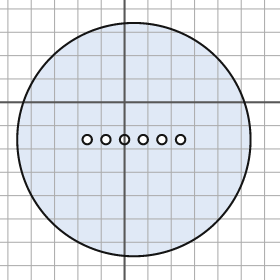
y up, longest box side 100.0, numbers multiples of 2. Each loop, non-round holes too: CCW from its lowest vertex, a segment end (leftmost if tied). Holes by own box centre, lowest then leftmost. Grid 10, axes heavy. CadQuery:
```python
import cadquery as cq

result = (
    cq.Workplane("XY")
    .moveTo(4.0, -16.0)
    .circle(50.0)
    .moveTo(-16.0, -16.0)
    .circle(2.0)
    .moveTo(-8.0, -16.0)
    .circle(2.0)
    .moveTo(0.0, -16.0)
    .circle(2.0)
    .moveTo(8.0, -16.0)
    .circle(2.0)
    .moveTo(16.0, -16.0)
    .circle(2.0)
    .moveTo(24.0, -16.0)
    .circle(2.0)
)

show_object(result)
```